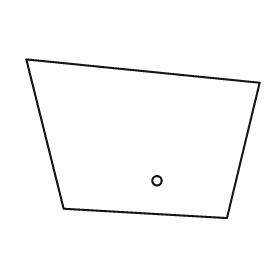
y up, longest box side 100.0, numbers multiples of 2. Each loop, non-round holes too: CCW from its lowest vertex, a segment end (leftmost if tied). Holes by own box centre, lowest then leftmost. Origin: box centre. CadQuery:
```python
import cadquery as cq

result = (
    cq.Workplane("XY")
    .moveTo(36.0, -34.0)
    .lineTo(50.0, 24.0)
    .lineTo(-50.0, 34.0)
    .lineTo(-34.0, -30.0)
    .close()
    .moveTo(6.0, -18.0)
    .circle(2.0)
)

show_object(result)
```